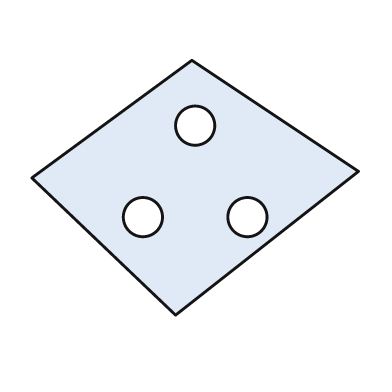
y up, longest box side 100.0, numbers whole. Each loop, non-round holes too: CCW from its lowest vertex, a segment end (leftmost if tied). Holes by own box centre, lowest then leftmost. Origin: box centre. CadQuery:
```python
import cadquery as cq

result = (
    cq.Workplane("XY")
    .moveTo(-6.0, -39.0)
    .lineTo(50.0, 5.0)
    .lineTo(-1.0, 39.0)
    .lineTo(-50.0, 3.0)
    .close()
    .moveTo(-16.0, -9.0)
    .circle(6.0)
    .moveTo(16.0, -9.0)
    .circle(6.0)
    .moveTo(0.0, 19.0)
    .circle(6.0)
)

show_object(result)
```